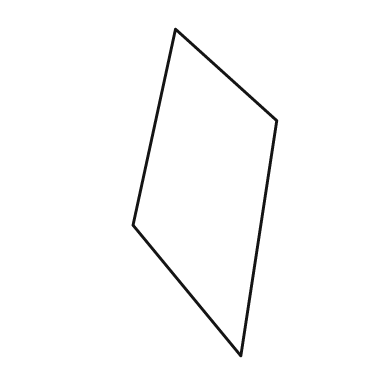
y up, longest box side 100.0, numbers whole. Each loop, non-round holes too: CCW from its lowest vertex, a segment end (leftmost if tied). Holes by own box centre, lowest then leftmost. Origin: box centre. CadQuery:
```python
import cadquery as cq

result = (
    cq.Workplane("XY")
    .moveTo(11.0, -50.0)
    .lineTo(22.0, 22.0)
    .lineTo(-9.0, 50.0)
    .lineTo(-22.0, -10.0)
    .close()
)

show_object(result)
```